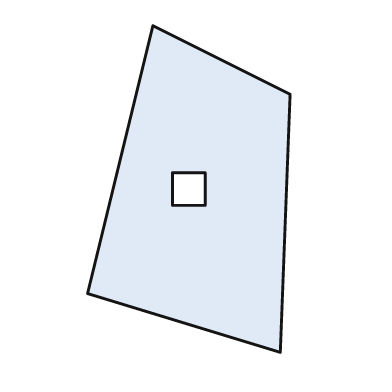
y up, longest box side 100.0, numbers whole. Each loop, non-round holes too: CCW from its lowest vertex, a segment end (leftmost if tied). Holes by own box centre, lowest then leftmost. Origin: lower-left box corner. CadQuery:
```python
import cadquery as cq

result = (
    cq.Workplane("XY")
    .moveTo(59.0, 0.0)
    .lineTo(62.0, 79.0)
    .lineTo(20.0, 100.0)
    .lineTo(0.0, 18.0)
    .close()
    .moveTo(26.0, 45.0)
    .lineTo(36.0, 45.0)
    .lineTo(36.0, 55.0)
    .lineTo(26.0, 55.0)
    .close()
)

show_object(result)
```